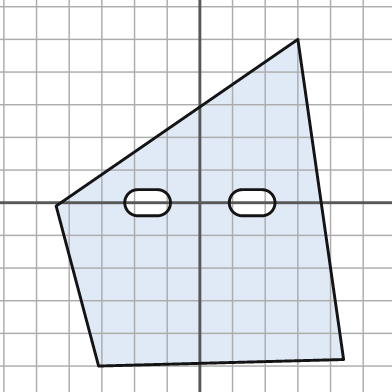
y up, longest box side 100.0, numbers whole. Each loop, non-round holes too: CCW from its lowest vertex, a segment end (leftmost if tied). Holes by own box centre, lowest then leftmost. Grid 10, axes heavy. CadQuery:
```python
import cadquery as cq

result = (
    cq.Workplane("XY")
    .moveTo(-31.0, -50.0)
    .lineTo(44.0, -48.0)
    .lineTo(30.0, 50.0)
    .lineTo(-44.0, -1.0)
    .close()
    .moveTo(-19.0, -4.0)
    .lineTo(-13.0, -4.0)
    .threePointArc((-9.0, 0.0), (-13.0, 4.0))
    .lineTo(-19.0, 4.0)
    .threePointArc((-23.0, 0.0), (-19.0, -4.0))
    .close()
    .moveTo(13.0, -4.0)
    .lineTo(19.0, -4.0)
    .threePointArc((23.0, 0.0), (19.0, 4.0))
    .lineTo(13.0, 4.0)
    .threePointArc((9.0, 0.0), (13.0, -4.0))
    .close()
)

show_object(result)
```